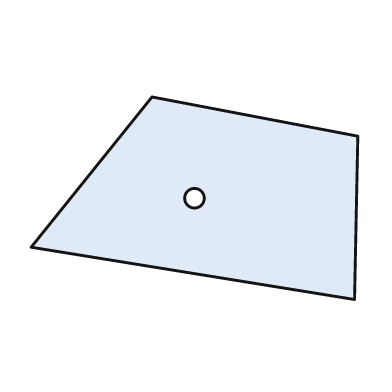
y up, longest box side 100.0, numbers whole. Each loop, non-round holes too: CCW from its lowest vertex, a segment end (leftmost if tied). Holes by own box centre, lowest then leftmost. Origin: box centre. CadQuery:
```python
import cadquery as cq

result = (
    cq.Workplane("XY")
    .moveTo(49.0, -31.0)
    .lineTo(50.0, 19.0)
    .lineTo(-13.0, 31.0)
    .lineTo(-50.0, -15.0)
    .close()
    .moveTo(0.0, 0.0)
    .circle(3.0)
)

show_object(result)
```